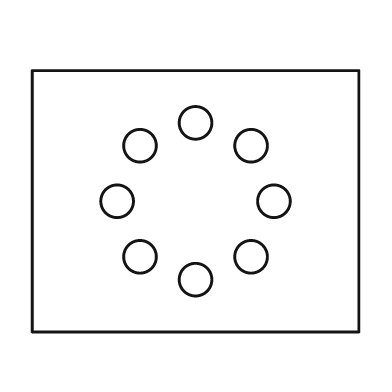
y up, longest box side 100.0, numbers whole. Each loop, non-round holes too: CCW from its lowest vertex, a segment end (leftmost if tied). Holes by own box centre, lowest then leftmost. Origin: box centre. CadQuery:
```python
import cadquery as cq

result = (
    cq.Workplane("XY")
    .moveTo(-50.0, -40.0)
    .lineTo(50.0, -40.0)
    .lineTo(50.0, 40.0)
    .lineTo(-50.0, 40.0)
    .close()
    .moveTo(0.0, -24.0)
    .circle(5.0)
    .moveTo(-17.0, -17.0)
    .circle(5.0)
    .moveTo(17.0, -17.0)
    .circle(5.0)
    .moveTo(-24.0, 0.0)
    .circle(5.0)
    .moveTo(24.0, 0.0)
    .circle(5.0)
    .moveTo(-17.0, 17.0)
    .circle(5.0)
    .moveTo(17.0, 17.0)
    .circle(5.0)
    .moveTo(0.0, 24.0)
    .circle(5.0)
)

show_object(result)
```